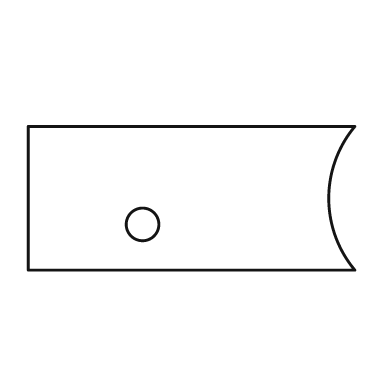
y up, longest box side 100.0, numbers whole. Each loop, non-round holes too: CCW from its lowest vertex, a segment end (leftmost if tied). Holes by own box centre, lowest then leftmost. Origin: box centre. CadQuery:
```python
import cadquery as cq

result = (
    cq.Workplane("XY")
    .moveTo(-50.0, -22.0)
    .lineTo(50.0, -22.0)
    .threePointArc((42.0, 0.0), (50.0, 22.0))
    .lineTo(-50.0, 22.0)
    .close()
    .moveTo(-15.0, -8.0)
    .circle(5.0)
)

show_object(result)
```